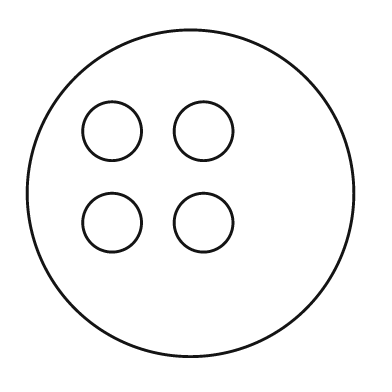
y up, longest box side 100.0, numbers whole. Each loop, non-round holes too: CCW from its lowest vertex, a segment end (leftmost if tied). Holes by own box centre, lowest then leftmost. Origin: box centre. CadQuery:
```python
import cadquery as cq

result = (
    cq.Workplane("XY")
    .moveTo(0.0, 0.0)
    .circle(50.0)
    .moveTo(-24.0, -9.0)
    .circle(9.0)
    .moveTo(4.0, -9.0)
    .circle(9.0)
    .moveTo(-24.0, 19.0)
    .circle(9.0)
    .moveTo(4.0, 19.0)
    .circle(9.0)
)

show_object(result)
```